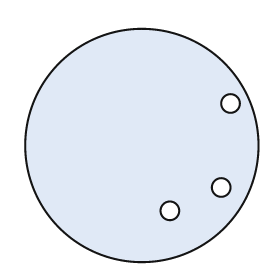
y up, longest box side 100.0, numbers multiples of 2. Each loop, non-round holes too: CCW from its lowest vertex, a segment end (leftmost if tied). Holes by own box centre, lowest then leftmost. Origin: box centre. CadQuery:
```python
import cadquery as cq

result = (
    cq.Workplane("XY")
    .moveTo(0.0, 0.0)
    .circle(50.0)
    .moveTo(12.0, -28.0)
    .circle(4.0)
    .moveTo(34.0, -18.0)
    .circle(4.0)
    .moveTo(38.0, 18.0)
    .circle(4.0)
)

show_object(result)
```